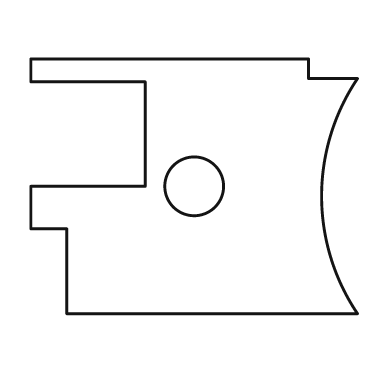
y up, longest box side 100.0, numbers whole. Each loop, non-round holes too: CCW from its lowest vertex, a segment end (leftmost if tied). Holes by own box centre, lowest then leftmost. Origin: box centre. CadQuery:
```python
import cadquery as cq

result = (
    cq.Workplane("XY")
    .moveTo(-39.0, -39.0)
    .lineTo(50.0, -39.0)
    .threePointArc((39.0, -3.0), (50.0, 33.0))
    .lineTo(35.0, 33.0)
    .lineTo(35.0, 39.0)
    .lineTo(-50.0, 39.0)
    .lineTo(-50.0, 32.0)
    .lineTo(-15.0, 32.0)
    .lineTo(-15.0, 0.0)
    .lineTo(-50.0, 0.0)
    .lineTo(-50.0, -13.0)
    .lineTo(-39.0, -13.0)
    .close()
    .moveTo(0.0, 0.0)
    .circle(9.0)
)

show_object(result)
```